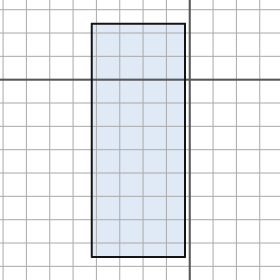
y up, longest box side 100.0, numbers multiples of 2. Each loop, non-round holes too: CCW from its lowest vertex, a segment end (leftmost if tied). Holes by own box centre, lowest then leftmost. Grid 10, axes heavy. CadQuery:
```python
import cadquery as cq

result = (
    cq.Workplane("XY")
    .moveTo(-42.0, -76.0)
    .lineTo(-2.0, -76.0)
    .lineTo(-2.0, 24.0)
    .lineTo(-42.0, 24.0)
    .close()
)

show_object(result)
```